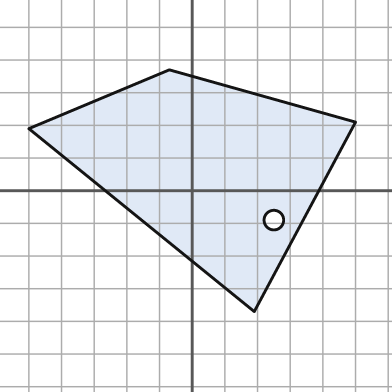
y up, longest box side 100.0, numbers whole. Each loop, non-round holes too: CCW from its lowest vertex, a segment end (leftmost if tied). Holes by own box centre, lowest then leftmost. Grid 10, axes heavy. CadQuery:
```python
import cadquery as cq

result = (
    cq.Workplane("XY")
    .moveTo(19.0, -37.0)
    .lineTo(50.0, 21.0)
    .lineTo(-7.0, 37.0)
    .lineTo(-50.0, 19.0)
    .close()
    .moveTo(25.0, -9.0)
    .circle(3.0)
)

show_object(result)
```